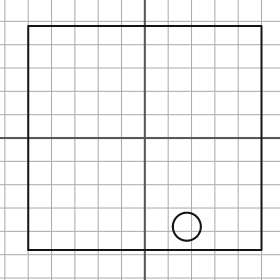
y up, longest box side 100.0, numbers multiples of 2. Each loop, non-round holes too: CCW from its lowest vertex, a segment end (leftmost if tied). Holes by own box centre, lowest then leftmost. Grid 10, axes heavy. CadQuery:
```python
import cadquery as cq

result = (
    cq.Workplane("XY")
    .moveTo(-50.0, -48.0)
    .lineTo(50.0, -48.0)
    .lineTo(50.0, 48.0)
    .lineTo(-50.0, 48.0)
    .close()
    .moveTo(18.0, -38.0)
    .circle(6.0)
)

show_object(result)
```